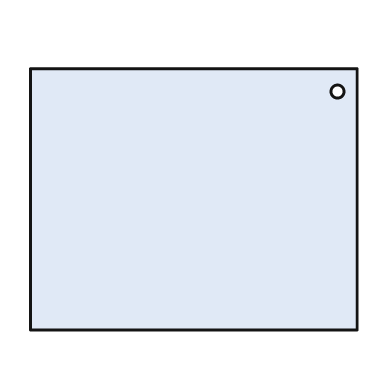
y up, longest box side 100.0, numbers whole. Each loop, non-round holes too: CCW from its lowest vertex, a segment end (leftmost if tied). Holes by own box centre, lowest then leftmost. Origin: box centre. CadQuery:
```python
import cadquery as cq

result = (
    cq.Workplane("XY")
    .moveTo(-50.0, -40.0)
    .lineTo(50.0, -40.0)
    .lineTo(50.0, 40.0)
    .lineTo(-50.0, 40.0)
    .close()
    .moveTo(44.0, 33.0)
    .circle(2.0)
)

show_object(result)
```